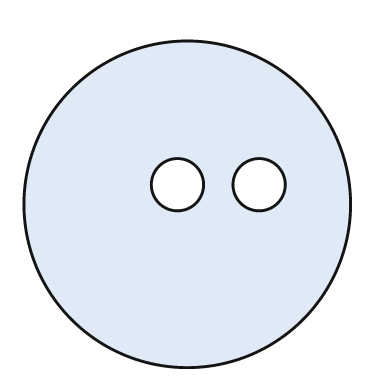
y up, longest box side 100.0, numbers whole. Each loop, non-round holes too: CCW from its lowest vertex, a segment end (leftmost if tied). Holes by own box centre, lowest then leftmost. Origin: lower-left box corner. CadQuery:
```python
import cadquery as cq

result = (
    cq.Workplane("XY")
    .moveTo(50.0, 50.0)
    .circle(50.0)
    .moveTo(47.0, 56.0)
    .circle(8.0)
    .moveTo(72.0, 56.0)
    .circle(8.0)
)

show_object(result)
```